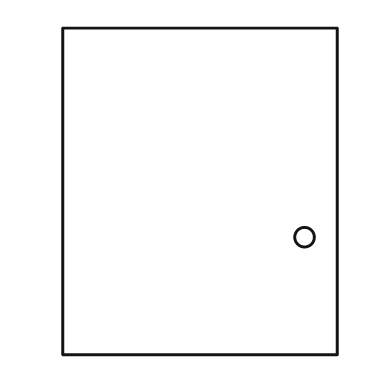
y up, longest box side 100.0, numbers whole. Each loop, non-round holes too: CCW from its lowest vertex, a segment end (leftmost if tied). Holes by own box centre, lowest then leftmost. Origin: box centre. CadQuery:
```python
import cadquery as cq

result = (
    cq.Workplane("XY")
    .moveTo(-42.0, -50.0)
    .lineTo(42.0, -50.0)
    .lineTo(42.0, 50.0)
    .lineTo(-42.0, 50.0)
    .close()
    .moveTo(32.0, -14.0)
    .circle(3.0)
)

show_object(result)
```